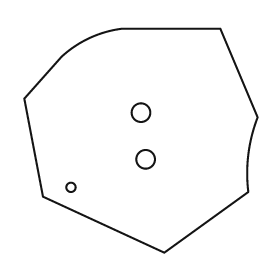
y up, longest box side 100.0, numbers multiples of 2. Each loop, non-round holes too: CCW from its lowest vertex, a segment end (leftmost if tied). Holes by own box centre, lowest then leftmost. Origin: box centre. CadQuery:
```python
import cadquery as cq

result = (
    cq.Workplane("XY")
    .moveTo(10.0, -48.0)
    .lineTo(46.0, -22.0)
    .threePointArc((46.0, -6.0), (50.0, 10.0))
    .lineTo(34.0, 48.0)
    .lineTo(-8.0, 48.0)
    .threePointArc((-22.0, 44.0), (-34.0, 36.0))
    .lineTo(-50.0, 18.0)
    .lineTo(-42.0, -24.0)
    .close()
    .moveTo(-30.0, -20.0)
    .circle(2.0)
    .moveTo(2.0, -8.0)
    .circle(4.0)
    .moveTo(0.0, 12.0)
    .circle(4.0)
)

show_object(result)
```